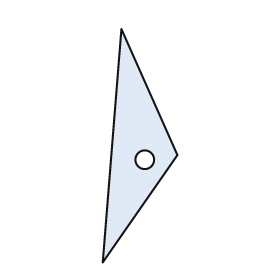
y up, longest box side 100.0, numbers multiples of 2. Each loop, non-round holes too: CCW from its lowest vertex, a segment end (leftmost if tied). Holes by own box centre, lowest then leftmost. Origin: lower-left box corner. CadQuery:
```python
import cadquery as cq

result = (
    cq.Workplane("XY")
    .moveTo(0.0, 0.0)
    .lineTo(32.0, 46.0)
    .lineTo(8.0, 100.0)
    .close()
    .moveTo(18.0, 44.0)
    .circle(4.0)
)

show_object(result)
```